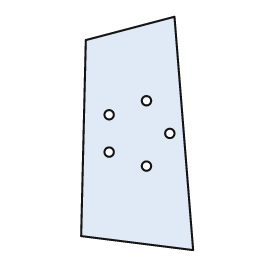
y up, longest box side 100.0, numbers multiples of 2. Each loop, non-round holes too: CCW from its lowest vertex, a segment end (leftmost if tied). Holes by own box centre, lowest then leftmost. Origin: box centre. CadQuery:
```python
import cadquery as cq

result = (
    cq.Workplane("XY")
    .moveTo(24.0, -50.0)
    .lineTo(16.0, 50.0)
    .lineTo(-22.0, 40.0)
    .lineTo(-24.0, -44.0)
    .close()
    .moveTo(4.0, -14.0)
    .circle(2.0)
    .moveTo(-12.0, -8.0)
    .circle(2.0)
    .moveTo(14.0, 0.0)
    .circle(2.0)
    .moveTo(-12.0, 8.0)
    .circle(2.0)
    .moveTo(4.0, 14.0)
    .circle(2.0)
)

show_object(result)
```